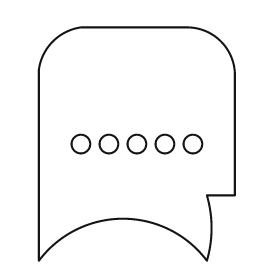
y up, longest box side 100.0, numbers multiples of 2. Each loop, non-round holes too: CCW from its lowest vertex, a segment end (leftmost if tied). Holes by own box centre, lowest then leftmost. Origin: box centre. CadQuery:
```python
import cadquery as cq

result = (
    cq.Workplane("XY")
    .moveTo(-42.0, -50.0)
    .threePointArc((-6.0, -32.0), (30.0, -50.0))
    .threePointArc((32.0, -36.0), (30.0, -22.0))
    .lineTo(42.0, -22.0)
    .lineTo(42.0, 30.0)
    .threePointArc((36.0, 44.0), (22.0, 50.0))
    .lineTo(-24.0, 50.0)
    .threePointArc((-36.0, 44.0), (-42.0, 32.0))
    .close()
    .moveTo(-24.0, 0.0)
    .circle(4.0)
    .moveTo(-12.0, 0.0)
    .circle(4.0)
    .moveTo(0.0, 0.0)
    .circle(4.0)
    .moveTo(12.0, 0.0)
    .circle(4.0)
    .moveTo(24.0, 0.0)
    .circle(4.0)
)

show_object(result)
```